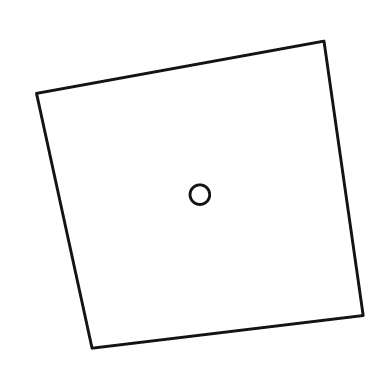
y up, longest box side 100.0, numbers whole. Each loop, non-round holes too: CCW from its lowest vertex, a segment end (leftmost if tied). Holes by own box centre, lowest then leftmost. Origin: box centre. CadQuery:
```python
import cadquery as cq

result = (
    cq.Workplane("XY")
    .moveTo(-33.0, -47.0)
    .lineTo(50.0, -37.0)
    .lineTo(38.0, 47.0)
    .lineTo(-50.0, 31.0)
    .close()
    .moveTo(0.0, 0.0)
    .circle(3.0)
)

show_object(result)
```